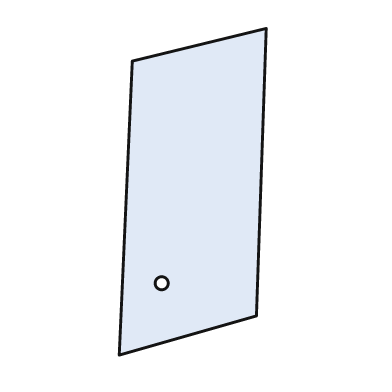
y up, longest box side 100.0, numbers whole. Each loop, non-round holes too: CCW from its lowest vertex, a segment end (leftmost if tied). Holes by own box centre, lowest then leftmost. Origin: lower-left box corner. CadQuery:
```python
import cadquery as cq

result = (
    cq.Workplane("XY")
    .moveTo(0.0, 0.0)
    .lineTo(42.0, 12.0)
    .lineTo(45.0, 100.0)
    .lineTo(4.0, 90.0)
    .close()
    .moveTo(13.0, 22.0)
    .circle(2.0)
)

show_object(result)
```